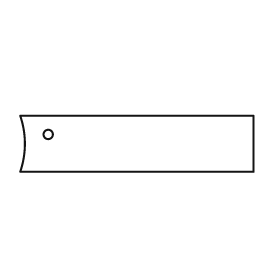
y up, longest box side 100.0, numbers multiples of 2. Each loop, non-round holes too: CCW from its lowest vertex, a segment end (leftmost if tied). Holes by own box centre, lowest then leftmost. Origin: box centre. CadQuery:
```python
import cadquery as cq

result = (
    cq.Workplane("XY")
    .moveTo(-50.0, -12.0)
    .lineTo(50.0, -12.0)
    .lineTo(50.0, 12.0)
    .lineTo(-50.0, 12.0)
    .threePointArc((-48.0, 0.0), (-50.0, -12.0))
    .close()
    .moveTo(-38.0, 4.0)
    .circle(2.0)
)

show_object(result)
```